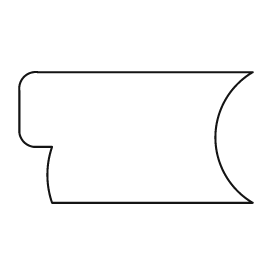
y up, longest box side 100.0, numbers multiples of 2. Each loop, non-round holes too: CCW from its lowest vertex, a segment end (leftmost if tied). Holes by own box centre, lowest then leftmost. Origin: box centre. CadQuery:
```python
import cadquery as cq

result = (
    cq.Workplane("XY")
    .moveTo(-36.0, -28.0)
    .lineTo(50.0, -28.0)
    .threePointArc((34.0, 0.0), (50.0, 28.0))
    .lineTo(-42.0, 28.0)
    .threePointArc((-48.0, 26.0), (-50.0, 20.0))
    .lineTo(-50.0, 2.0)
    .threePointArc((-48.0, -2.0), (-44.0, -4.0))
    .lineTo(-36.0, -4.0)
    .threePointArc((-38.0, -16.0), (-36.0, -28.0))
    .close()
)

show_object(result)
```